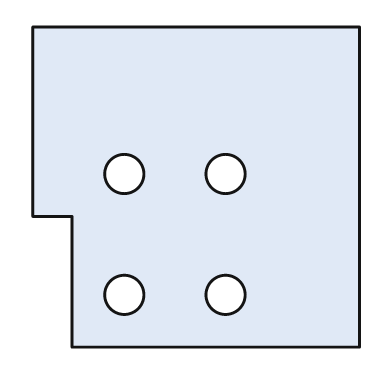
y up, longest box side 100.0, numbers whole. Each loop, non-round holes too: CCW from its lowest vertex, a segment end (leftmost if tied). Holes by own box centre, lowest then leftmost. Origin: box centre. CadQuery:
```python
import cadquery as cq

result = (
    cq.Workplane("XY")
    .moveTo(-38.0, -49.0)
    .lineTo(50.0, -49.0)
    .lineTo(50.0, 49.0)
    .lineTo(-50.0, 49.0)
    .lineTo(-50.0, -9.0)
    .lineTo(-38.0, -9.0)
    .close()
    .moveTo(-22.0, -33.0)
    .circle(6.0)
    .moveTo(9.0, -33.0)
    .circle(6.0)
    .moveTo(-22.0, 4.0)
    .circle(6.0)
    .moveTo(9.0, 4.0)
    .circle(6.0)
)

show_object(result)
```